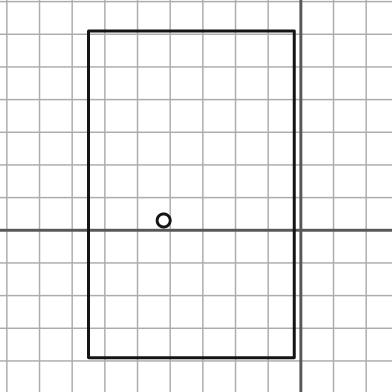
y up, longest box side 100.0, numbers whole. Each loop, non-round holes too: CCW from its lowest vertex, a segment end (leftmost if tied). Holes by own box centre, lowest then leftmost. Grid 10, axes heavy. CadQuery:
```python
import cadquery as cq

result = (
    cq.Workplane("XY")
    .moveTo(-65.0, -39.0)
    .lineTo(-2.0, -39.0)
    .lineTo(-2.0, 61.0)
    .lineTo(-65.0, 61.0)
    .close()
    .moveTo(-42.0, 3.0)
    .circle(2.0)
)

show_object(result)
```